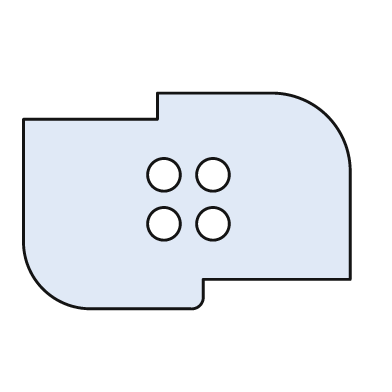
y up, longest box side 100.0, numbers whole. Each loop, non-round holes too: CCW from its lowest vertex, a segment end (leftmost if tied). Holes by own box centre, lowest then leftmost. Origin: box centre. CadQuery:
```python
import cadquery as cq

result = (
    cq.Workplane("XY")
    .moveTo(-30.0, -33.0)
    .lineTo(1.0, -33.0)
    .threePointArc((4.0, -32.0), (5.0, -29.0))
    .lineTo(5.0, -24.0)
    .lineTo(50.0, -24.0)
    .lineTo(50.0, 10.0)
    .threePointArc((43.0, 26.0), (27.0, 33.0))
    .lineTo(-9.0, 33.0)
    .lineTo(-9.0, 25.0)
    .lineTo(-50.0, 25.0)
    .lineTo(-50.0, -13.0)
    .threePointArc((-44.0, -27.0), (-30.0, -33.0))
    .close()
    .moveTo(-7.0, -7.0)
    .circle(5.0)
    .moveTo(8.0, -7.0)
    .circle(5.0)
    .moveTo(-7.0, 8.0)
    .circle(5.0)
    .moveTo(8.0, 8.0)
    .circle(5.0)
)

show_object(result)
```